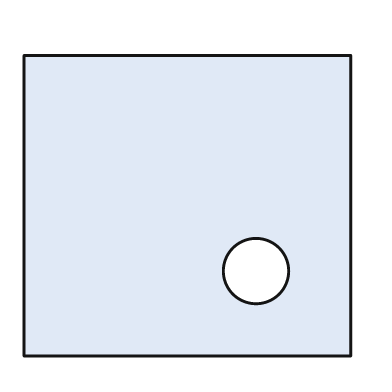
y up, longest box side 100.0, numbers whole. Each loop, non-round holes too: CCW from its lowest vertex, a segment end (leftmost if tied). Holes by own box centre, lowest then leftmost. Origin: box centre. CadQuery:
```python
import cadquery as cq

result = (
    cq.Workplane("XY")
    .moveTo(-50.0, -46.0)
    .lineTo(50.0, -46.0)
    .lineTo(50.0, 46.0)
    .lineTo(-50.0, 46.0)
    .close()
    .moveTo(21.0, -20.0)
    .circle(10.0)
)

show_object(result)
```